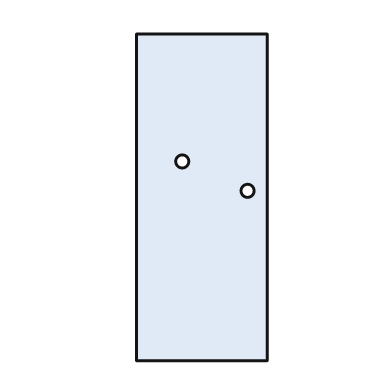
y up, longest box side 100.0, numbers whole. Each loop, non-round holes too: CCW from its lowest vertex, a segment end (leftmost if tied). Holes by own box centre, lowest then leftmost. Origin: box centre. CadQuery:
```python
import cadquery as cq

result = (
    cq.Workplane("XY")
    .moveTo(-20.0, -50.0)
    .lineTo(20.0, -50.0)
    .lineTo(20.0, 50.0)
    .lineTo(-20.0, 50.0)
    .close()
    .moveTo(14.0, 2.0)
    .circle(2.0)
    .moveTo(-6.0, 11.0)
    .circle(2.0)
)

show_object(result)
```